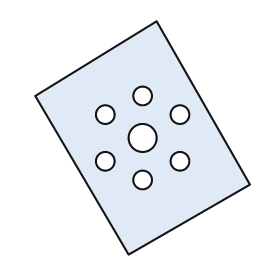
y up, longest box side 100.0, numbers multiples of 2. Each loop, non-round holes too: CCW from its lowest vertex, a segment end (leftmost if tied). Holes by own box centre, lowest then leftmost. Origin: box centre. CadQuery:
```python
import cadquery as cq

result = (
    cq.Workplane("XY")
    .moveTo(-6.0, -50.0)
    .lineTo(46.0, -20.0)
    .lineTo(6.0, 50.0)
    .lineTo(-46.0, 18.0)
    .close()
    .moveTo(0.0, -18.0)
    .circle(4.0)
    .moveTo(-16.0, -10.0)
    .circle(4.0)
    .moveTo(16.0, -10.0)
    .circle(4.0)
    .moveTo(0.0, 0.0)
    .circle(6.0)
    .moveTo(-16.0, 10.0)
    .circle(4.0)
    .moveTo(16.0, 10.0)
    .circle(4.0)
    .moveTo(0.0, 18.0)
    .circle(4.0)
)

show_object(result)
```